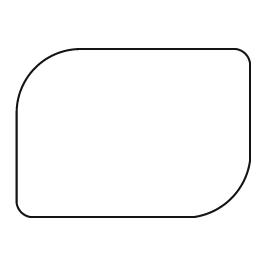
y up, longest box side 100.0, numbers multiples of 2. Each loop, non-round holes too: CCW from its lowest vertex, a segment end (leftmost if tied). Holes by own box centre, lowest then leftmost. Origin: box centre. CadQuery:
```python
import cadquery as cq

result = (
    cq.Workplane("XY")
    .moveTo(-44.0, -36.0)
    .lineTo(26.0, -36.0)
    .threePointArc((42.0, -28.0), (50.0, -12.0))
    .lineTo(50.0, 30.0)
    .threePointArc((48.0, 34.0), (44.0, 36.0))
    .lineTo(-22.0, 36.0)
    .threePointArc((-42.0, 28.0), (-50.0, 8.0))
    .lineTo(-50.0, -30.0)
    .threePointArc((-48.0, -34.0), (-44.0, -36.0))
    .close()
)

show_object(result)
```